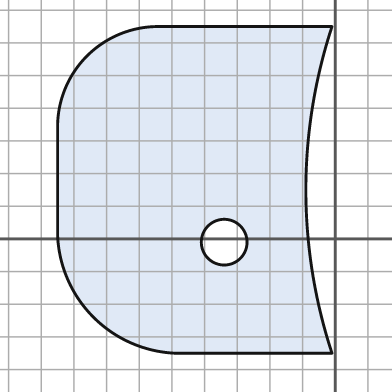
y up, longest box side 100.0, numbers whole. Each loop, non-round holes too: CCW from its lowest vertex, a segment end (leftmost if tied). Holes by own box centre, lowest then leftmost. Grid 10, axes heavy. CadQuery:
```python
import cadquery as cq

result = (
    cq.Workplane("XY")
    .moveTo(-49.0, -35.0)
    .lineTo(-1.0, -35.0)
    .threePointArc((-9.0, 15.0), (-1.0, 65.0))
    .lineTo(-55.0, 65.0)
    .threePointArc((-76.0, 56.0), (-85.0, 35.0))
    .lineTo(-85.0, 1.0)
    .threePointArc((-74.0, -24.0), (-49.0, -35.0))
    .close()
    .moveTo(-34.0, -1.0)
    .circle(7.0)
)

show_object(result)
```